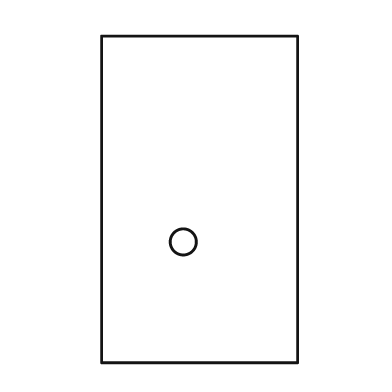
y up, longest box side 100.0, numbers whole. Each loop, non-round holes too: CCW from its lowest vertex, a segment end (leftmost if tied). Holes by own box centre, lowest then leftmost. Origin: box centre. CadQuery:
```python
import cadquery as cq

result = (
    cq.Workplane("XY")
    .moveTo(-30.0, -50.0)
    .lineTo(30.0, -50.0)
    .lineTo(30.0, 50.0)
    .lineTo(-30.0, 50.0)
    .close()
    .moveTo(-5.0, -13.0)
    .circle(4.0)
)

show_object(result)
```